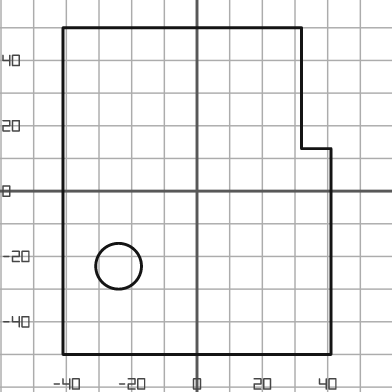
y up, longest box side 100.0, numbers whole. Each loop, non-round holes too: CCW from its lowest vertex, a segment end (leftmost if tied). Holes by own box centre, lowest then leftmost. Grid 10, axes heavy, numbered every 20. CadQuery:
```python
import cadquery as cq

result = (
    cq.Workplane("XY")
    .moveTo(-41.0, -50.0)
    .lineTo(41.0, -50.0)
    .lineTo(41.0, 13.0)
    .lineTo(32.0, 13.0)
    .lineTo(32.0, 50.0)
    .lineTo(-41.0, 50.0)
    .close()
    .moveTo(-24.0, -23.0)
    .circle(7.0)
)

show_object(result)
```